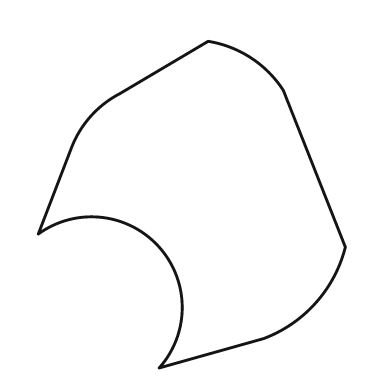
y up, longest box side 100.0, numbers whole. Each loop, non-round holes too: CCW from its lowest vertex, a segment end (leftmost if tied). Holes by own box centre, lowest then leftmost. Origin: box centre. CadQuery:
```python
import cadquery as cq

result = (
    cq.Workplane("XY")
    .moveTo(-10.0, -50.0)
    .lineTo(22.0, -41.0)
    .threePointArc((38.0, -30.0), (47.0, -13.0))
    .lineTo(28.0, 35.0)
    .threePointArc((18.0, 45.0), (5.0, 50.0))
    .lineTo(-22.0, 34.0)
    .threePointArc((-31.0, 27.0), (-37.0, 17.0))
    .lineTo(-47.0, -9.0)
    .threePointArc((-10.0, -13.0), (-10.0, -50.0))
    .close()
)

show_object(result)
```